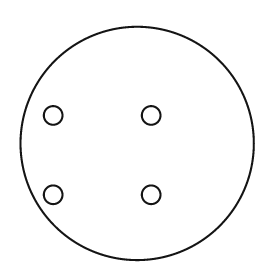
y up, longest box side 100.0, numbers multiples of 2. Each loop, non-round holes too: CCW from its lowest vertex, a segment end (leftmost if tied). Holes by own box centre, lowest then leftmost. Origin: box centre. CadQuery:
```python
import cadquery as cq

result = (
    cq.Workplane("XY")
    .moveTo(0.0, 0.0)
    .circle(50.0)
    .moveTo(-36.0, -22.0)
    .circle(4.0)
    .moveTo(6.0, -22.0)
    .circle(4.0)
    .moveTo(-36.0, 12.0)
    .circle(4.0)
    .moveTo(6.0, 12.0)
    .circle(4.0)
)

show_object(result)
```